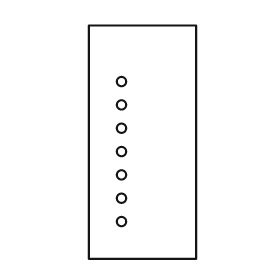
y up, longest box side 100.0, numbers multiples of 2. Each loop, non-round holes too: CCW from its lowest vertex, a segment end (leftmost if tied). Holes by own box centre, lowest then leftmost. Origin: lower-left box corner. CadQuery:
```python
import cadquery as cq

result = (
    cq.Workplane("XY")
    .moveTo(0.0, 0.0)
    .lineTo(46.0, 0.0)
    .lineTo(46.0, 100.0)
    .lineTo(0.0, 100.0)
    .close()
    .moveTo(14.0, 16.0)
    .circle(2.0)
    .moveTo(14.0, 26.0)
    .circle(2.0)
    .moveTo(14.0, 36.0)
    .circle(2.0)
    .moveTo(14.0, 46.0)
    .circle(2.0)
    .moveTo(14.0, 56.0)
    .circle(2.0)
    .moveTo(14.0, 66.0)
    .circle(2.0)
    .moveTo(14.0, 76.0)
    .circle(2.0)
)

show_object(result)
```